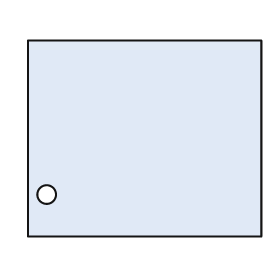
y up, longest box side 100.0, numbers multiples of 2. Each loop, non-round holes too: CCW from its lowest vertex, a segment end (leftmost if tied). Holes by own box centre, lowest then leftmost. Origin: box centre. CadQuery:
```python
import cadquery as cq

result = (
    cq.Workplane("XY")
    .moveTo(-50.0, -42.0)
    .lineTo(50.0, -42.0)
    .lineTo(50.0, 42.0)
    .lineTo(-50.0, 42.0)
    .close()
    .moveTo(-42.0, -24.0)
    .circle(4.0)
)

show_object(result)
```